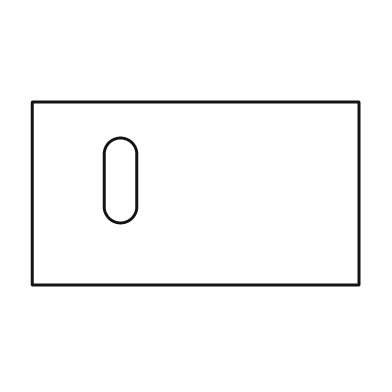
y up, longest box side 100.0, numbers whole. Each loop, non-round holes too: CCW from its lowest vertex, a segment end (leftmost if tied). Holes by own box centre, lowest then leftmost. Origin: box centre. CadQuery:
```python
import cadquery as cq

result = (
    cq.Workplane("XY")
    .moveTo(-50.0, -28.0)
    .lineTo(50.0, -28.0)
    .lineTo(50.0, 28.0)
    .lineTo(-50.0, 28.0)
    .close()
    .moveTo(-28.0, -4.0)
    .threePointArc((-23.0, -9.0), (-18.0, -4.0))
    .lineTo(-18.0, 12.0)
    .threePointArc((-23.0, 17.0), (-28.0, 12.0))
    .close()
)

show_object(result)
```